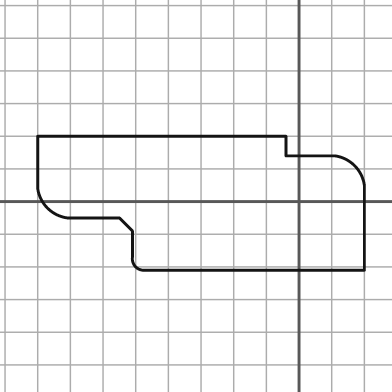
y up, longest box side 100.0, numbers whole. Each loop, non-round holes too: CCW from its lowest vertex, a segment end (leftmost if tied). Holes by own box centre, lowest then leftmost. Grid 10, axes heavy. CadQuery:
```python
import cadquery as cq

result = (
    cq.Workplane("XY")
    .moveTo(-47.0, -21.0)
    .lineTo(20.0, -21.0)
    .lineTo(20.0, 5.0)
    .threePointArc((17.0, 11.0), (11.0, 14.0))
    .lineTo(-4.0, 14.0)
    .lineTo(-4.0, 20.0)
    .lineTo(-80.0, 20.0)
    .lineTo(-80.0, 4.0)
    .threePointArc((-77.0, -2.0), (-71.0, -5.0))
    .lineTo(-55.0, -5.0)
    .lineTo(-51.0, -9.0)
    .lineTo(-51.0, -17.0)
    .threePointArc((-50.0, -20.0), (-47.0, -21.0))
    .close()
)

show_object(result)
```